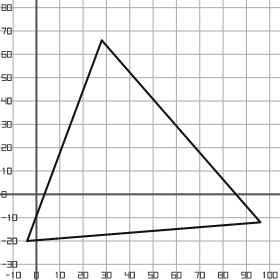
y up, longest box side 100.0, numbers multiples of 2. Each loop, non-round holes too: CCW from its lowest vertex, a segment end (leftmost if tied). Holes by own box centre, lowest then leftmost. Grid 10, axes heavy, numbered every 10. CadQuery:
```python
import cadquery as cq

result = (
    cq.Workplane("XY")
    .moveTo(-4.0, -20.0)
    .lineTo(96.0, -12.0)
    .lineTo(28.0, 66.0)
    .close()
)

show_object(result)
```